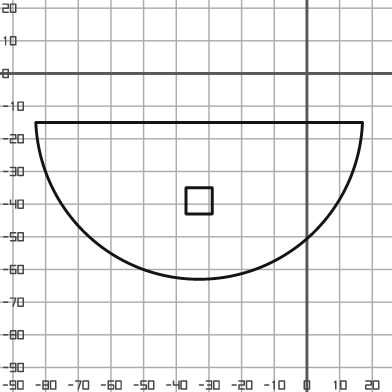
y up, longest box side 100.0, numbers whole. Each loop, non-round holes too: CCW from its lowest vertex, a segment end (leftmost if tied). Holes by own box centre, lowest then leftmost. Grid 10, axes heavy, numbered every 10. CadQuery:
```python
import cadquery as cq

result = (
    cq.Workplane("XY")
    .moveTo(-83.0, -15.0)
    .threePointArc((-33.0, -63.0), (17.0, -15.0))
    .close()
    .moveTo(-37.0, -43.0)
    .lineTo(-29.0, -43.0)
    .lineTo(-29.0, -35.0)
    .lineTo(-37.0, -35.0)
    .close()
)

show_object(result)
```